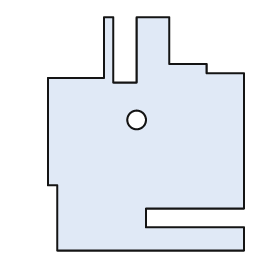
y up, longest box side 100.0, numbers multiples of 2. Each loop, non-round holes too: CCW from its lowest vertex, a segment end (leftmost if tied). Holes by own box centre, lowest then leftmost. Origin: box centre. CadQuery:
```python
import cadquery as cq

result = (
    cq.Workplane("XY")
    .moveTo(-38.0, -50.0)
    .lineTo(42.0, -50.0)
    .lineTo(42.0, -40.0)
    .lineTo(0.0, -40.0)
    .lineTo(0.0, -32.0)
    .lineTo(42.0, -32.0)
    .lineTo(42.0, 26.0)
    .lineTo(26.0, 26.0)
    .lineTo(26.0, 30.0)
    .lineTo(10.0, 30.0)
    .lineTo(10.0, 50.0)
    .lineTo(-4.0, 50.0)
    .lineTo(-4.0, 22.0)
    .lineTo(-14.0, 22.0)
    .lineTo(-14.0, 50.0)
    .lineTo(-18.0, 50.0)
    .lineTo(-18.0, 24.0)
    .lineTo(-42.0, 24.0)
    .lineTo(-42.0, -22.0)
    .lineTo(-38.0, -22.0)
    .close()
    .moveTo(-4.0, 6.0)
    .circle(4.0)
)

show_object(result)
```